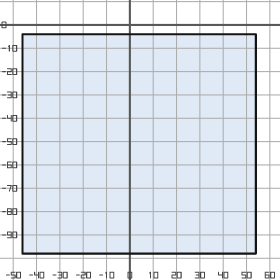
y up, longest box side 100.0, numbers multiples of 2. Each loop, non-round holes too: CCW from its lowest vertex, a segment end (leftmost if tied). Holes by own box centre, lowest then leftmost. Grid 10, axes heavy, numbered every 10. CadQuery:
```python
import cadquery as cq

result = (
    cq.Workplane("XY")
    .moveTo(-46.0, -98.0)
    .lineTo(54.0, -98.0)
    .lineTo(54.0, -4.0)
    .lineTo(-46.0, -4.0)
    .close()
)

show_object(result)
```